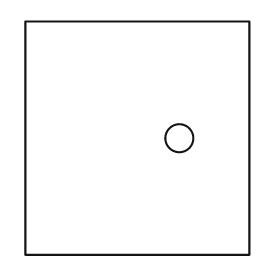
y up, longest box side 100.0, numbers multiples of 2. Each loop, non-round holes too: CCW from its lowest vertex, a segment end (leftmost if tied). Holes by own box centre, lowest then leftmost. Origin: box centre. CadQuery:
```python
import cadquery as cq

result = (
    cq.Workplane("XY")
    .moveTo(-48.0, -50.0)
    .lineTo(48.0, -50.0)
    .lineTo(48.0, 50.0)
    .lineTo(-48.0, 50.0)
    .close()
    .moveTo(18.0, 0.0)
    .circle(6.0)
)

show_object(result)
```